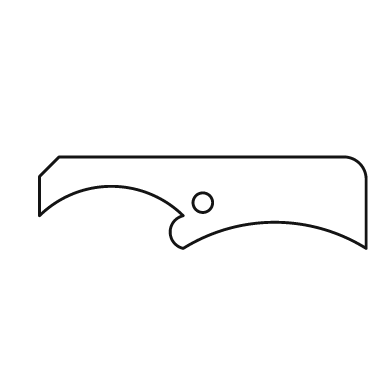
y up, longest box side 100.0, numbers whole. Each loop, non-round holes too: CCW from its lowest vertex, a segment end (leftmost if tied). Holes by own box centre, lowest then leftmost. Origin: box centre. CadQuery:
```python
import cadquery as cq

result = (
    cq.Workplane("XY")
    .moveTo(-6.0, -14.0)
    .threePointArc((22.0, -6.0), (50.0, -14.0))
    .lineTo(50.0, 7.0)
    .threePointArc((48.0, 12.0), (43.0, 14.0))
    .lineTo(-44.0, 14.0)
    .lineTo(-50.0, 8.0)
    .lineTo(-50.0, -4.0)
    .threePointArc((-28.0, 5.0), (-6.0, -4.0))
    .threePointArc((-10.0, -9.0), (-6.0, -14.0))
    .close()
    .moveTo(0.0, 0.0)
    .circle(3.0)
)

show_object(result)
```